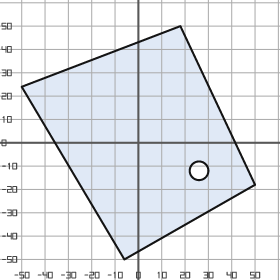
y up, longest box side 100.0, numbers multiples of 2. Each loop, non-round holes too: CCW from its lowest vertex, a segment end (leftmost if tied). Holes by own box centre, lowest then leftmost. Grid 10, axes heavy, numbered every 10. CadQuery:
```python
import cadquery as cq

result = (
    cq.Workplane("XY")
    .moveTo(-6.0, -50.0)
    .lineTo(50.0, -18.0)
    .lineTo(18.0, 50.0)
    .lineTo(-50.0, 24.0)
    .close()
    .moveTo(26.0, -12.0)
    .circle(4.0)
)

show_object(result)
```